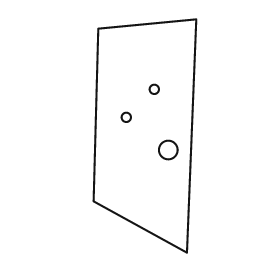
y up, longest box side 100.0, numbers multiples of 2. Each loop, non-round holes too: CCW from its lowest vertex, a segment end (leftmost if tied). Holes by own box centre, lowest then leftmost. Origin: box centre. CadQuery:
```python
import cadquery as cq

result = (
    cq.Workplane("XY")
    .moveTo(18.0, -50.0)
    .lineTo(22.0, 50.0)
    .lineTo(-20.0, 46.0)
    .lineTo(-22.0, -28.0)
    .close()
    .moveTo(10.0, -6.0)
    .circle(4.0)
    .moveTo(-8.0, 8.0)
    .circle(2.0)
    .moveTo(4.0, 20.0)
    .circle(2.0)
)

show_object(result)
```